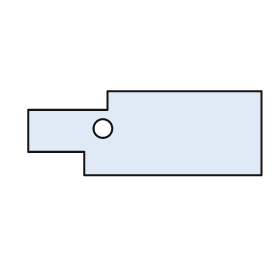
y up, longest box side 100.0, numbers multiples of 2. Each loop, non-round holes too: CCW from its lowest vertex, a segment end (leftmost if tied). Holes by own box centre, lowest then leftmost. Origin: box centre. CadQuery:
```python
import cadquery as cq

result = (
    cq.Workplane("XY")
    .moveTo(-26.0, -18.0)
    .lineTo(50.0, -18.0)
    .lineTo(50.0, 18.0)
    .lineTo(-16.0, 18.0)
    .lineTo(-16.0, 10.0)
    .lineTo(-50.0, 10.0)
    .lineTo(-50.0, -8.0)
    .lineTo(-26.0, -8.0)
    .close()
    .moveTo(-18.0, 2.0)
    .circle(4.0)
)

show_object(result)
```